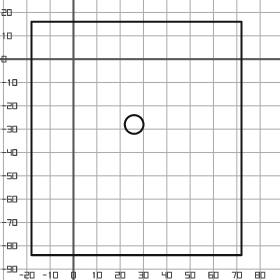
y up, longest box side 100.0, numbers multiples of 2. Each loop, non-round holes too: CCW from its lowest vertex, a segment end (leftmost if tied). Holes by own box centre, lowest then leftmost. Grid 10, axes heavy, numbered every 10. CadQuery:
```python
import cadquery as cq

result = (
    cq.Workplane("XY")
    .moveTo(-18.0, -84.0)
    .lineTo(72.0, -84.0)
    .lineTo(72.0, 16.0)
    .lineTo(-18.0, 16.0)
    .close()
    .moveTo(26.0, -28.0)
    .circle(4.0)
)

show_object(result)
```